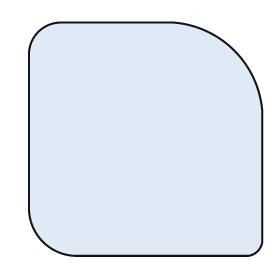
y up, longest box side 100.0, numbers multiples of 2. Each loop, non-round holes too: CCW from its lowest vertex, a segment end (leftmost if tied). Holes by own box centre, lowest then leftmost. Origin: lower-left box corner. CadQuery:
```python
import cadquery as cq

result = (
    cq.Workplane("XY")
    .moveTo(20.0, 0.0)
    .lineTo(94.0, 0.0)
    .threePointArc((98.0, 2.0), (100.0, 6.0))
    .lineTo(100.0, 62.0)
    .threePointArc((88.0, 88.0), (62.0, 100.0))
    .lineTo(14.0, 100.0)
    .threePointArc((4.0, 96.0), (0.0, 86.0))
    .lineTo(0.0, 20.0)
    .threePointArc((6.0, 6.0), (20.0, 0.0))
    .close()
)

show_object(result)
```